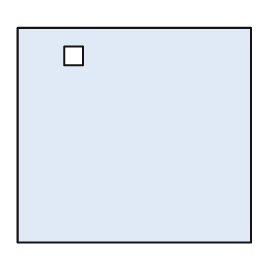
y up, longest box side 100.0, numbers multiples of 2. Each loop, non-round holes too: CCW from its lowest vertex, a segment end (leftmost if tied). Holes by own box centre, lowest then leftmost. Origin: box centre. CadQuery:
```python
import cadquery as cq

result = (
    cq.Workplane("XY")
    .moveTo(-50.0, -46.0)
    .lineTo(50.0, -46.0)
    .lineTo(50.0, 46.0)
    .lineTo(-50.0, 46.0)
    .close()
    .moveTo(-30.0, 30.0)
    .lineTo(-22.0, 30.0)
    .lineTo(-22.0, 38.0)
    .lineTo(-30.0, 38.0)
    .close()
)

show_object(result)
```